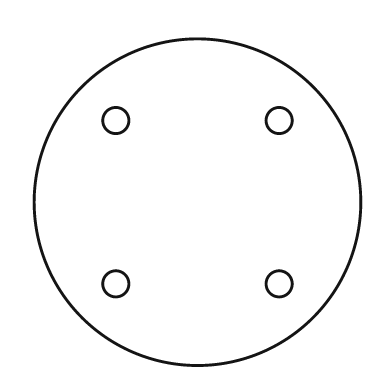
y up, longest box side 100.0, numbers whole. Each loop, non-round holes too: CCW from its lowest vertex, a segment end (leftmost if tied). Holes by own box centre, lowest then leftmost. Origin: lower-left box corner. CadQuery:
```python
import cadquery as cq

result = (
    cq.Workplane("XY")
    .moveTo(50.0, 50.0)
    .circle(50.0)
    .moveTo(25.0, 25.0)
    .circle(4.0)
    .moveTo(75.0, 25.0)
    .circle(4.0)
    .moveTo(25.0, 75.0)
    .circle(4.0)
    .moveTo(75.0, 75.0)
    .circle(4.0)
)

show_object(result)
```